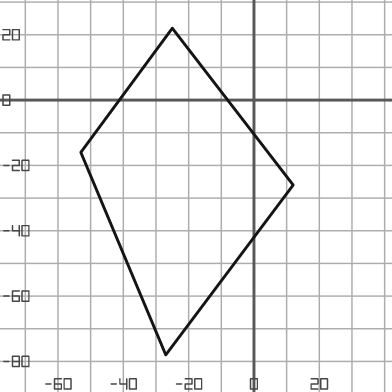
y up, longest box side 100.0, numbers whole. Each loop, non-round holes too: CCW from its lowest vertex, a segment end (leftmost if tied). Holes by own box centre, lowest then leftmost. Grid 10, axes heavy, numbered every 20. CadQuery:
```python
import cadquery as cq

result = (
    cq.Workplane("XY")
    .moveTo(-27.0, -78.0)
    .lineTo(12.0, -26.0)
    .lineTo(-25.0, 22.0)
    .lineTo(-53.0, -16.0)
    .close()
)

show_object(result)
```